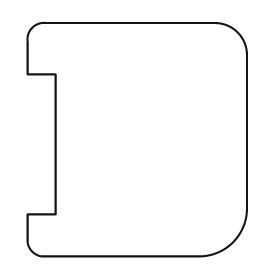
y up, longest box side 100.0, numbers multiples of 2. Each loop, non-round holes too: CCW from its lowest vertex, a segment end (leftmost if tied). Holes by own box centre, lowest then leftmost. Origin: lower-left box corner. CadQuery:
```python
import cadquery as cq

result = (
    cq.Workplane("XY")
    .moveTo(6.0, 0.0)
    .lineTo(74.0, 0.0)
    .threePointArc((88.0, 6.0), (94.0, 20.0))
    .lineTo(94.0, 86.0)
    .threePointArc((90.0, 96.0), (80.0, 100.0))
    .lineTo(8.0, 100.0)
    .threePointArc((2.0, 98.0), (0.0, 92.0))
    .lineTo(0.0, 78.0)
    .lineTo(12.0, 78.0)
    .lineTo(12.0, 18.0)
    .lineTo(0.0, 18.0)
    .lineTo(0.0, 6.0)
    .threePointArc((2.0, 2.0), (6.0, 0.0))
    .close()
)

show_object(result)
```